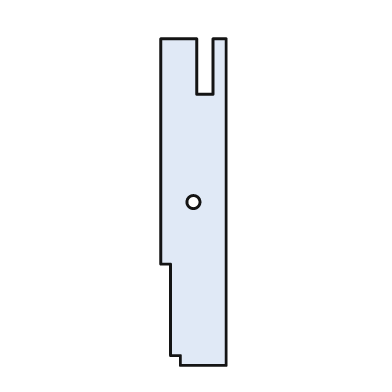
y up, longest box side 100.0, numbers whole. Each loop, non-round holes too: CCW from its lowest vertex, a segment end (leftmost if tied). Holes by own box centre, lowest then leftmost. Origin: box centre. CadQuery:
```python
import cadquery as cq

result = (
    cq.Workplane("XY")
    .moveTo(-4.0, -50.0)
    .lineTo(10.0, -50.0)
    .lineTo(10.0, 50.0)
    .lineTo(6.0, 50.0)
    .lineTo(6.0, 33.0)
    .lineTo(1.0, 33.0)
    .lineTo(1.0, 50.0)
    .lineTo(-10.0, 50.0)
    .lineTo(-10.0, -19.0)
    .lineTo(-7.0, -19.0)
    .lineTo(-7.0, -47.0)
    .lineTo(-4.0, -47.0)
    .close()
    .moveTo(0.0, 0.0)
    .circle(2.0)
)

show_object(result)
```